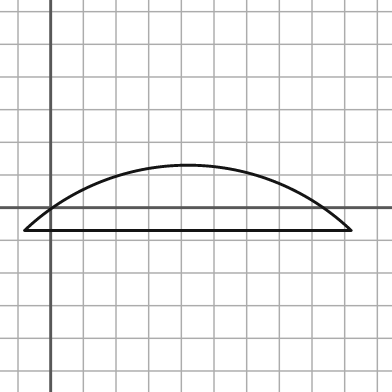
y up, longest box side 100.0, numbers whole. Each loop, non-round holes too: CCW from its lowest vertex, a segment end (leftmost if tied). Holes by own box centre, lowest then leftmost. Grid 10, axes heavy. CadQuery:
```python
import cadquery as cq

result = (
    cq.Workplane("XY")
    .moveTo(-8.0, -7.0)
    .lineTo(92.0, -7.0)
    .threePointArc((42.0, 13.0), (-8.0, -7.0))
    .close()
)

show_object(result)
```